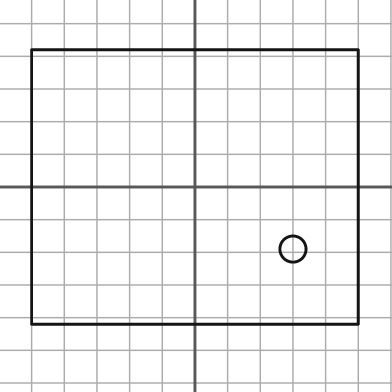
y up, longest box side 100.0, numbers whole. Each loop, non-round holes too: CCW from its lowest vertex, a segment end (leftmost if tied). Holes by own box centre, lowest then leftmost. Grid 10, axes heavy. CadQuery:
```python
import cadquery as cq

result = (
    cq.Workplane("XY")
    .moveTo(-50.0, -42.0)
    .lineTo(50.0, -42.0)
    .lineTo(50.0, 42.0)
    .lineTo(-50.0, 42.0)
    .close()
    .moveTo(30.0, -19.0)
    .circle(4.0)
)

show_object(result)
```